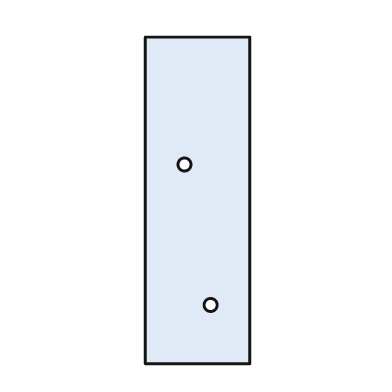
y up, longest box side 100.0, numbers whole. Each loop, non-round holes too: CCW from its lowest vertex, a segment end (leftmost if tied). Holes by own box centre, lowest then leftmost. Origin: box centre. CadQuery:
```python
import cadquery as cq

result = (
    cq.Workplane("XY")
    .moveTo(-16.0, -50.0)
    .lineTo(16.0, -50.0)
    .lineTo(16.0, 50.0)
    .lineTo(-16.0, 50.0)
    .close()
    .moveTo(4.0, -32.0)
    .circle(2.0)
    .moveTo(-4.0, 11.0)
    .circle(2.0)
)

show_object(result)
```